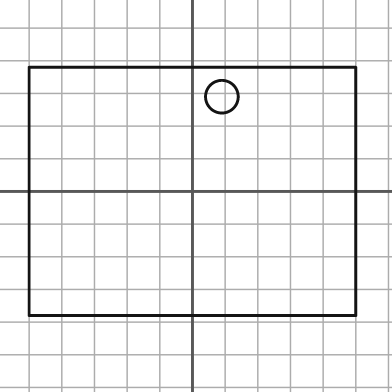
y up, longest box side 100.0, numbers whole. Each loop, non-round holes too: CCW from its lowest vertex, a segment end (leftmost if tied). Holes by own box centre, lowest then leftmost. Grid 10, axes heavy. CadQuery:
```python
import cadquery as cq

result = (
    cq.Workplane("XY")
    .moveTo(-50.0, -38.0)
    .lineTo(50.0, -38.0)
    .lineTo(50.0, 38.0)
    .lineTo(-50.0, 38.0)
    .close()
    .moveTo(9.0, 29.0)
    .circle(5.0)
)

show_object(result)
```